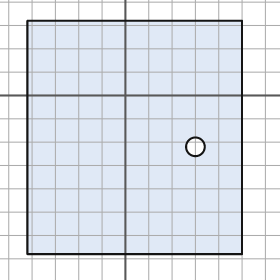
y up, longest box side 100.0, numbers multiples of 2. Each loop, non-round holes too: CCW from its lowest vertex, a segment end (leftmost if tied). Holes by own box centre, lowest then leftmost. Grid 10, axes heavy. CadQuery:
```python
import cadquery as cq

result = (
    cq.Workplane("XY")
    .moveTo(-42.0, -68.0)
    .lineTo(50.0, -68.0)
    .lineTo(50.0, 32.0)
    .lineTo(-42.0, 32.0)
    .close()
    .moveTo(30.0, -22.0)
    .circle(4.0)
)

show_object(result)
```